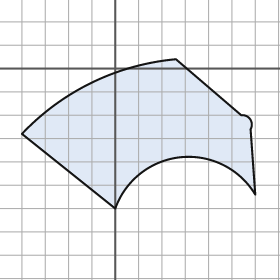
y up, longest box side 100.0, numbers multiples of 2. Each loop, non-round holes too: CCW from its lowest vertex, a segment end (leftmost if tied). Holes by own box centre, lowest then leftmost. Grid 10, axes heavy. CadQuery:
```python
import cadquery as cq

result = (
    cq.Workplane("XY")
    .moveTo(0.0, -60.0)
    .threePointArc((28.0, -38.0), (60.0, -54.0))
    .lineTo(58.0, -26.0)
    .threePointArc((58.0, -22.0), (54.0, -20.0))
    .lineTo(26.0, 4.0)
    .threePointArc((-10.0, -6.0), (-40.0, -28.0))
    .close()
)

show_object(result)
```